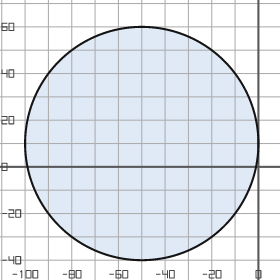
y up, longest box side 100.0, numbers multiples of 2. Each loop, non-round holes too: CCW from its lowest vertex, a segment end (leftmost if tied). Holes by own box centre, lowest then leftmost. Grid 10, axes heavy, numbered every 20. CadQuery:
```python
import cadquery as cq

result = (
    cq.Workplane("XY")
    .moveTo(-50.0, 10.0)
    .circle(50.0)
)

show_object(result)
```